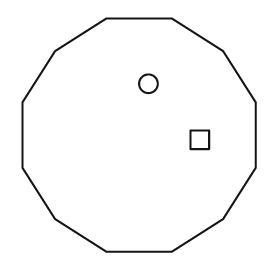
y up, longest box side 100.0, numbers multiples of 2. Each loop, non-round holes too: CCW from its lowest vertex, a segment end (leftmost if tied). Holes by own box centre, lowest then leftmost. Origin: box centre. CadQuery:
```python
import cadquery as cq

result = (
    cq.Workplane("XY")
    .moveTo(-14.0, -50.0)
    .lineTo(14.0, -50.0)
    .lineTo(36.0, -36.0)
    .lineTo(50.0, -14.0)
    .lineTo(50.0, 14.0)
    .lineTo(36.0, 36.0)
    .lineTo(14.0, 50.0)
    .lineTo(-14.0, 50.0)
    .lineTo(-36.0, 36.0)
    .lineTo(-50.0, 14.0)
    .lineTo(-50.0, -14.0)
    .lineTo(-36.0, -36.0)
    .close()
    .moveTo(22.0, -6.0)
    .lineTo(30.0, -6.0)
    .lineTo(30.0, 2.0)
    .lineTo(22.0, 2.0)
    .close()
    .moveTo(4.0, 22.0)
    .circle(4.0)
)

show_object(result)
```